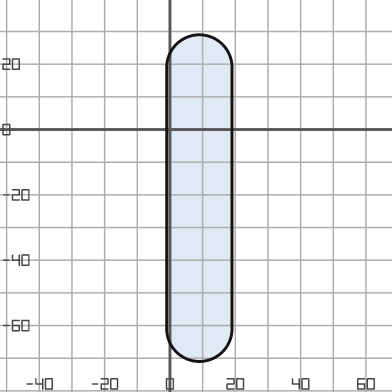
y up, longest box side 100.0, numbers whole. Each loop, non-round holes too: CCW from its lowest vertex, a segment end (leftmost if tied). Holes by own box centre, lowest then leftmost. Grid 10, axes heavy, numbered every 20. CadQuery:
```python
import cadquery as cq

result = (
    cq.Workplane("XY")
    .moveTo(-1.0, -61.0)
    .threePointArc((9.0, -71.0), (19.0, -61.0))
    .lineTo(19.0, 19.0)
    .threePointArc((9.0, 29.0), (-1.0, 19.0))
    .close()
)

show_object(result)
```